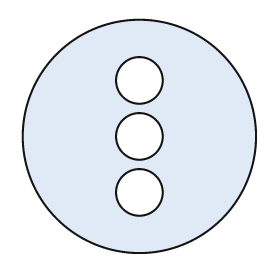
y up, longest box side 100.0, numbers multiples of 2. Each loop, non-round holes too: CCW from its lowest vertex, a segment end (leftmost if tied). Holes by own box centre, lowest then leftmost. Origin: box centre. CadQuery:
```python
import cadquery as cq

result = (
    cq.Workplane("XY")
    .moveTo(0.0, 0.0)
    .circle(50.0)
    .moveTo(0.0, -24.0)
    .circle(10.0)
    .moveTo(0.0, 0.0)
    .circle(10.0)
    .moveTo(0.0, 24.0)
    .circle(10.0)
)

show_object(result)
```